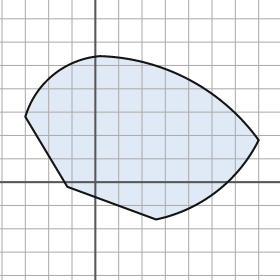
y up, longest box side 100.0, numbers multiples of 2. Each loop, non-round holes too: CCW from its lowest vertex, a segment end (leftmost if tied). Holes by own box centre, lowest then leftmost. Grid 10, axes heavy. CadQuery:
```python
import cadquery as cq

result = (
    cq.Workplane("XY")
    .moveTo(26.0, -16.0)
    .threePointArc((52.0, -4.0), (70.0, 18.0))
    .threePointArc((40.0, 44.0), (2.0, 54.0))
    .threePointArc((-18.0, 46.0), (-30.0, 28.0))
    .lineTo(-12.0, -2.0)
    .close()
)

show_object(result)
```